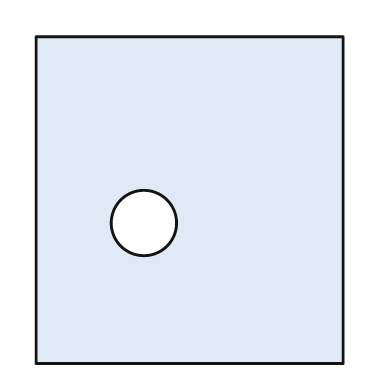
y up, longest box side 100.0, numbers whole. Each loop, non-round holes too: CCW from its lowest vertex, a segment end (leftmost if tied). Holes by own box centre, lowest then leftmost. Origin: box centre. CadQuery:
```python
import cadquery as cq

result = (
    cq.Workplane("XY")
    .moveTo(-47.0, -50.0)
    .lineTo(47.0, -50.0)
    .lineTo(47.0, 50.0)
    .lineTo(-47.0, 50.0)
    .close()
    .moveTo(-14.0, -7.0)
    .circle(10.0)
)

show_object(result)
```